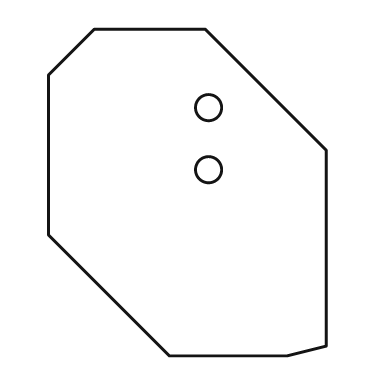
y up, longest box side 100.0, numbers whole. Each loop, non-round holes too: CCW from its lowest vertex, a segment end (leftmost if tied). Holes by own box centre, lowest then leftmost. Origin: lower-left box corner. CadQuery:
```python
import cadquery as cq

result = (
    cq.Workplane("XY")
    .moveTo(37.0, 0.0)
    .lineTo(73.0, 0.0)
    .lineTo(85.0, 3.0)
    .lineTo(85.0, 63.0)
    .lineTo(48.0, 100.0)
    .lineTo(14.0, 100.0)
    .lineTo(0.0, 86.0)
    .lineTo(0.0, 37.0)
    .close()
    .moveTo(49.0, 57.0)
    .circle(4.0)
    .moveTo(49.0, 76.0)
    .circle(4.0)
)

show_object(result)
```